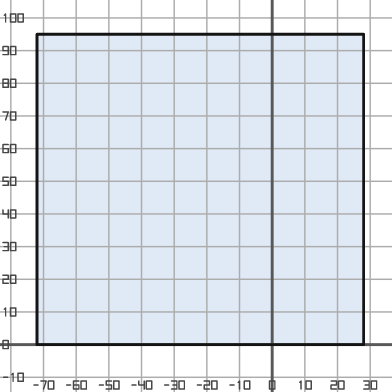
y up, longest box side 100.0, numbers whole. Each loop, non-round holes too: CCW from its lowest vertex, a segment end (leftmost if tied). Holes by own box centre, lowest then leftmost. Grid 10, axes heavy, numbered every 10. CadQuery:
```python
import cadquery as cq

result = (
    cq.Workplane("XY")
    .moveTo(-72.0, 0.0)
    .lineTo(28.0, 0.0)
    .lineTo(28.0, 95.0)
    .lineTo(-72.0, 95.0)
    .close()
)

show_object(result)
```